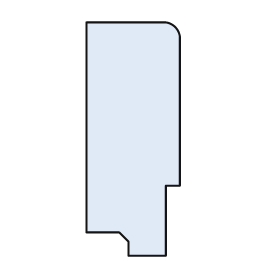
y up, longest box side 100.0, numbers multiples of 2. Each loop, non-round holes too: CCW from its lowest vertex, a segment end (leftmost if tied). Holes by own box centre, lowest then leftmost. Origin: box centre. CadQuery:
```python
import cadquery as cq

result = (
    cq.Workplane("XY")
    .moveTo(-2.0, -50.0)
    .lineTo(14.0, -50.0)
    .lineTo(14.0, -20.0)
    .lineTo(20.0, -20.0)
    .lineTo(20.0, 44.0)
    .threePointArc((18.0, 48.0), (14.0, 50.0))
    .lineTo(-20.0, 50.0)
    .lineTo(-20.0, -40.0)
    .lineTo(-6.0, -40.0)
    .lineTo(-2.0, -44.0)
    .close()
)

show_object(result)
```